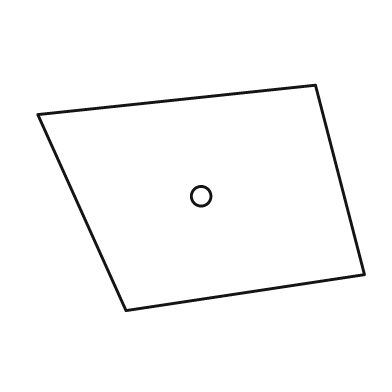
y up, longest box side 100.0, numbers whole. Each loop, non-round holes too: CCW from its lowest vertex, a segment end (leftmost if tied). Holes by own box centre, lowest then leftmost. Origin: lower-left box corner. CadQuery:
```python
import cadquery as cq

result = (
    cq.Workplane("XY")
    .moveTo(27.0, 0.0)
    .lineTo(100.0, 11.0)
    .lineTo(85.0, 69.0)
    .lineTo(0.0, 60.0)
    .close()
    .moveTo(50.0, 35.0)
    .circle(3.0)
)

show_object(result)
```